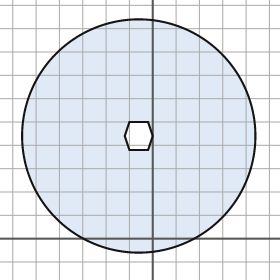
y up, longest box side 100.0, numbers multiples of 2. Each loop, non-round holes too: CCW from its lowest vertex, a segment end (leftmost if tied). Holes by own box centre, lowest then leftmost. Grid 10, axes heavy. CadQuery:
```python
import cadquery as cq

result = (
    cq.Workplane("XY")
    .moveTo(-6.0, 44.0)
    .circle(50.0)
    .moveTo(-10.0, 38.0)
    .lineTo(-2.0, 38.0)
    .lineTo(0.0, 44.0)
    .lineTo(-2.0, 50.0)
    .lineTo(-10.0, 50.0)
    .lineTo(-12.0, 44.0)
    .close()
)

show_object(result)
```